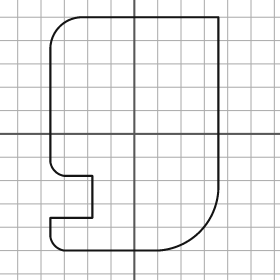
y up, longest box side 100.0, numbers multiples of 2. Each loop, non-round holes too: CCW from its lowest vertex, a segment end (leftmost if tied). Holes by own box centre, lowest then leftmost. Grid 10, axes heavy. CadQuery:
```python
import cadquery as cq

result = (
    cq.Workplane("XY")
    .moveTo(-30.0, -50.0)
    .lineTo(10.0, -50.0)
    .threePointArc((28.0, -42.0), (36.0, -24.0))
    .lineTo(36.0, 50.0)
    .lineTo(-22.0, 50.0)
    .threePointArc((-32.0, 46.0), (-36.0, 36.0))
    .lineTo(-36.0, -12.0)
    .threePointArc((-34.0, -16.0), (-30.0, -18.0))
    .lineTo(-18.0, -18.0)
    .lineTo(-18.0, -36.0)
    .lineTo(-36.0, -36.0)
    .lineTo(-36.0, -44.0)
    .threePointArc((-34.0, -48.0), (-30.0, -50.0))
    .close()
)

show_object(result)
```